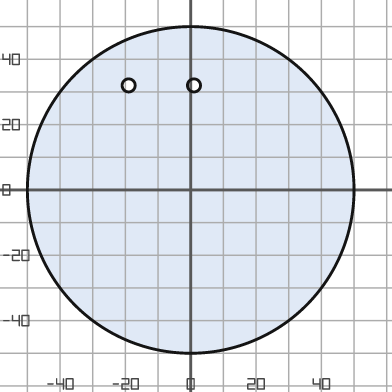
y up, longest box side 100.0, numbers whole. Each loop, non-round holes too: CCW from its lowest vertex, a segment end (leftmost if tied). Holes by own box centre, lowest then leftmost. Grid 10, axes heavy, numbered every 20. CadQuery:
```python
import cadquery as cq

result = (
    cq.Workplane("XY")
    .moveTo(0.0, 0.0)
    .circle(50.0)
    .moveTo(-19.0, 32.0)
    .circle(2.0)
    .moveTo(1.0, 32.0)
    .circle(2.0)
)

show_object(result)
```